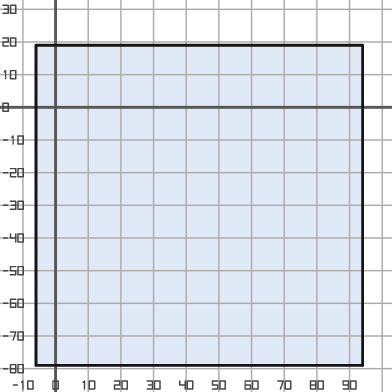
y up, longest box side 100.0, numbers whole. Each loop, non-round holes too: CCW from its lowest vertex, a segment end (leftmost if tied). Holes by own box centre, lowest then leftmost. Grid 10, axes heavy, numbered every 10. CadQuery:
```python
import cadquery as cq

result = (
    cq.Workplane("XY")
    .moveTo(-6.0, -79.0)
    .lineTo(94.0, -79.0)
    .lineTo(94.0, 19.0)
    .lineTo(-6.0, 19.0)
    .close()
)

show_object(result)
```